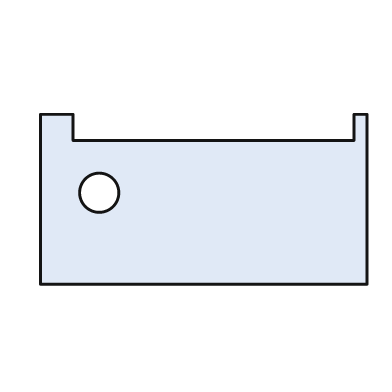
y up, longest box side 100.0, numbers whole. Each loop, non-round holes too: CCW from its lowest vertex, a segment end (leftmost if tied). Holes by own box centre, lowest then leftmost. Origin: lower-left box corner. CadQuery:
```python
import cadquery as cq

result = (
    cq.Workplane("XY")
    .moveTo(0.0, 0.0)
    .lineTo(100.0, 0.0)
    .lineTo(100.0, 52.0)
    .lineTo(96.0, 52.0)
    .lineTo(96.0, 44.0)
    .lineTo(10.0, 44.0)
    .lineTo(10.0, 52.0)
    .lineTo(0.0, 52.0)
    .close()
    .moveTo(18.0, 28.0)
    .circle(6.0)
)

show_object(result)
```